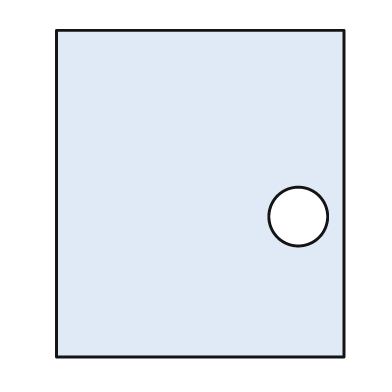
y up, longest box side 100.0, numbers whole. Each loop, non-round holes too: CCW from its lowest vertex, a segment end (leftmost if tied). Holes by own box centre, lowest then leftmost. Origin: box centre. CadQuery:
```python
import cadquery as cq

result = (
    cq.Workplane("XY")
    .moveTo(-44.0, -50.0)
    .lineTo(44.0, -50.0)
    .lineTo(44.0, 50.0)
    .lineTo(-44.0, 50.0)
    .close()
    .moveTo(30.0, -7.0)
    .circle(9.0)
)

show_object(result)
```